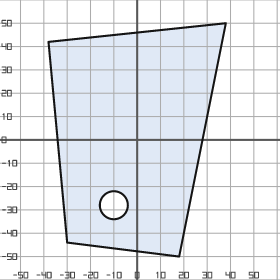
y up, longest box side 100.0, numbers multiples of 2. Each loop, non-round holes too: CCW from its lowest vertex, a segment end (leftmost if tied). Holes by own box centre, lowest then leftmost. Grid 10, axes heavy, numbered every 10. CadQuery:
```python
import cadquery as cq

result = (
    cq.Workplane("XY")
    .moveTo(18.0, -50.0)
    .lineTo(38.0, 50.0)
    .lineTo(-38.0, 42.0)
    .lineTo(-30.0, -44.0)
    .close()
    .moveTo(-10.0, -28.0)
    .circle(6.0)
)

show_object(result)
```